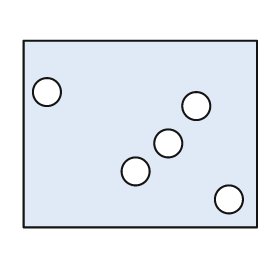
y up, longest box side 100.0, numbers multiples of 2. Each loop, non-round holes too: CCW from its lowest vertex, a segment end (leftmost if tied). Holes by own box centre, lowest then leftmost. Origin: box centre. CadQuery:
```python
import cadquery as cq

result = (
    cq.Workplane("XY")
    .moveTo(-50.0, -40.0)
    .lineTo(50.0, -40.0)
    .lineTo(50.0, 40.0)
    .lineTo(-50.0, 40.0)
    .close()
    .moveTo(38.0, -28.0)
    .circle(6.0)
    .moveTo(-2.0, -16.0)
    .circle(6.0)
    .moveTo(12.0, -4.0)
    .circle(6.0)
    .moveTo(24.0, 12.0)
    .circle(6.0)
    .moveTo(-40.0, 18.0)
    .circle(6.0)
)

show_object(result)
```